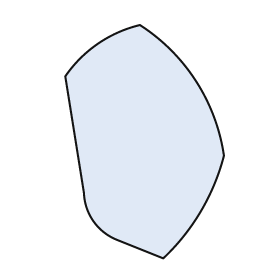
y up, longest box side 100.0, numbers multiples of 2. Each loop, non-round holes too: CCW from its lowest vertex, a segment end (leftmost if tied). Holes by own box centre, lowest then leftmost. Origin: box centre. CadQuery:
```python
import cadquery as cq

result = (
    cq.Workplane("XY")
    .moveTo(8.0, -50.0)
    .threePointArc((24.0, -30.0), (34.0, -6.0))
    .threePointArc((22.0, 26.0), (-2.0, 50.0))
    .threePointArc((-20.0, 42.0), (-34.0, 28.0))
    .lineTo(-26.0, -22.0)
    .threePointArc((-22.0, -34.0), (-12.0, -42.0))
    .close()
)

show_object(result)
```